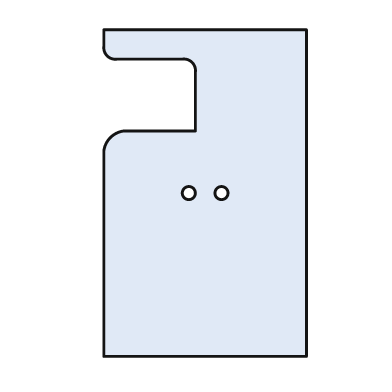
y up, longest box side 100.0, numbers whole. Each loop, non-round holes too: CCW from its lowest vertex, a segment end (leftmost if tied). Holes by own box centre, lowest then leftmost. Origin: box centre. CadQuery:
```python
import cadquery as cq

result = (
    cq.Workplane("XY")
    .moveTo(-31.0, -50.0)
    .lineTo(31.0, -50.0)
    .lineTo(31.0, 50.0)
    .lineTo(-31.0, 50.0)
    .lineTo(-31.0, 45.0)
    .threePointArc((-30.0, 42.0), (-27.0, 41.0))
    .lineTo(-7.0, 41.0)
    .threePointArc((-4.0, 40.0), (-3.0, 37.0))
    .lineTo(-3.0, 19.0)
    .lineTo(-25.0, 19.0)
    .threePointArc((-29.0, 17.0), (-31.0, 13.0))
    .close()
    .moveTo(-5.0, 0.0)
    .circle(2.0)
    .moveTo(5.0, 0.0)
    .circle(2.0)
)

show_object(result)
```